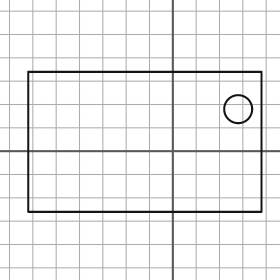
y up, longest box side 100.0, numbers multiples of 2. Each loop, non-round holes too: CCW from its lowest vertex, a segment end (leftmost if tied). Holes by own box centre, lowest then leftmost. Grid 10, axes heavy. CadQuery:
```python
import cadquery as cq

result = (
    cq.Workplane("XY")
    .moveTo(-62.0, -26.0)
    .lineTo(38.0, -26.0)
    .lineTo(38.0, 34.0)
    .lineTo(-62.0, 34.0)
    .close()
    .moveTo(28.0, 18.0)
    .circle(6.0)
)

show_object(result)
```